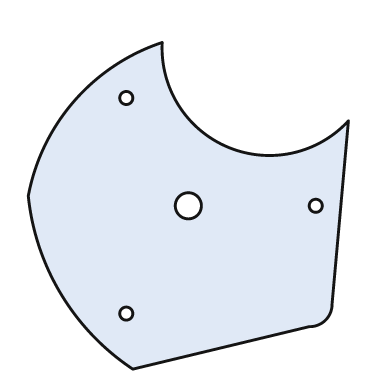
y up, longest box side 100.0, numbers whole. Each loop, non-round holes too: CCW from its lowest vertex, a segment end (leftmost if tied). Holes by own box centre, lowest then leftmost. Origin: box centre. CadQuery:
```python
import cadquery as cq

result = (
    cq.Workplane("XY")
    .moveTo(-17.0, -50.0)
    .lineTo(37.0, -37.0)
    .threePointArc((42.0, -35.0), (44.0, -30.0))
    .lineTo(49.0, 26.0)
    .threePointArc((12.0, 18.0), (-8.0, 50.0))
    .threePointArc((-35.0, 32.0), (-49.0, 3.0))
    .threePointArc((-39.0, -27.0), (-17.0, -50.0))
    .close()
    .moveTo(-19.0, -33.0)
    .circle(2.0)
    .moveTo(0.0, 0.0)
    .circle(4.0)
    .moveTo(39.0, 0.0)
    .circle(2.0)
    .moveTo(-19.0, 33.0)
    .circle(2.0)
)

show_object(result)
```